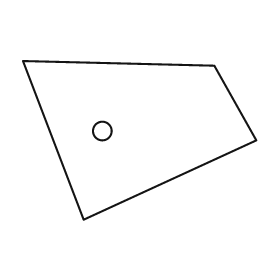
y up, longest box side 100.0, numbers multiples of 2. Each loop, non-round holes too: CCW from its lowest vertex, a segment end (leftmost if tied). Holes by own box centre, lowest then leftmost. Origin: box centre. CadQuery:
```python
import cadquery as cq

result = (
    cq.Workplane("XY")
    .moveTo(-24.0, -34.0)
    .lineTo(50.0, 0.0)
    .lineTo(32.0, 32.0)
    .lineTo(-50.0, 34.0)
    .close()
    .moveTo(-16.0, 4.0)
    .circle(4.0)
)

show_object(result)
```